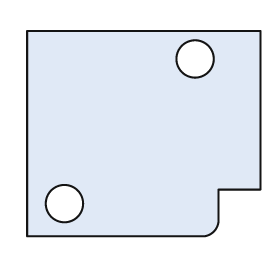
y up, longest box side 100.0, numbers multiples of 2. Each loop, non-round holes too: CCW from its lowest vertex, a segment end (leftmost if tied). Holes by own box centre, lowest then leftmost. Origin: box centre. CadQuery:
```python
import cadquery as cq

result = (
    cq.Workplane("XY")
    .moveTo(-50.0, -44.0)
    .lineTo(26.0, -44.0)
    .threePointArc((30.0, -42.0), (32.0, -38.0))
    .lineTo(32.0, -24.0)
    .lineTo(50.0, -24.0)
    .lineTo(50.0, 44.0)
    .lineTo(-50.0, 44.0)
    .close()
    .moveTo(-34.0, -30.0)
    .circle(8.0)
    .moveTo(22.0, 32.0)
    .circle(8.0)
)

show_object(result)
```